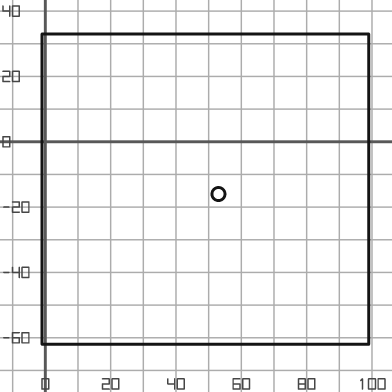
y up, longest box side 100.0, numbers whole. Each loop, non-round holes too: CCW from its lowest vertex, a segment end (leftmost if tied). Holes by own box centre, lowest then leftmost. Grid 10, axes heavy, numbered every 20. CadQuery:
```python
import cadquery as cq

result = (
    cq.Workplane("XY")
    .moveTo(-1.0, -62.0)
    .lineTo(99.0, -62.0)
    .lineTo(99.0, 33.0)
    .lineTo(-1.0, 33.0)
    .close()
    .moveTo(53.0, -16.0)
    .circle(2.0)
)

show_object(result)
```